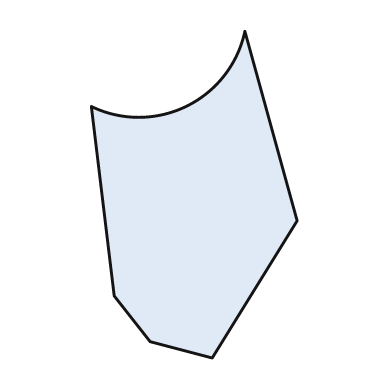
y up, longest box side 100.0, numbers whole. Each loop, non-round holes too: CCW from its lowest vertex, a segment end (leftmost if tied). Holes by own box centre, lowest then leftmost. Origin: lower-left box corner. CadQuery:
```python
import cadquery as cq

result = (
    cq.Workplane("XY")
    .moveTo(37.0, 0.0)
    .lineTo(63.0, 42.0)
    .lineTo(47.0, 100.0)
    .threePointArc((29.0, 77.0), (0.0, 77.0))
    .lineTo(7.0, 19.0)
    .lineTo(18.0, 5.0)
    .close()
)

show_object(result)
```